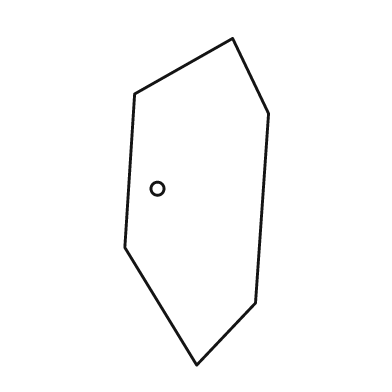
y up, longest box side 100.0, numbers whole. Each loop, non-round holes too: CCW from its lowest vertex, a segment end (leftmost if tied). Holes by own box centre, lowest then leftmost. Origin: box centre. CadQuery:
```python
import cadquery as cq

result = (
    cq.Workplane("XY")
    .moveTo(0.0, -50.0)
    .lineTo(18.0, -31.0)
    .lineTo(22.0, 27.0)
    .lineTo(11.0, 50.0)
    .lineTo(-19.0, 33.0)
    .lineTo(-22.0, -14.0)
    .close()
    .moveTo(-12.0, 4.0)
    .circle(2.0)
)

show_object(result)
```